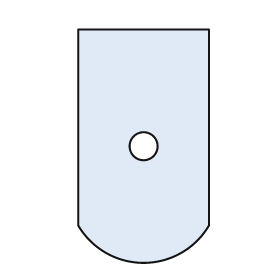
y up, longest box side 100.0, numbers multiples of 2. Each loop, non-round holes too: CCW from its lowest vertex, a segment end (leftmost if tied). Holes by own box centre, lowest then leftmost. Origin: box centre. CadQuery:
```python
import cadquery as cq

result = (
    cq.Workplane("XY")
    .moveTo(-28.0, -34.0)
    .threePointArc((0.0, -50.0), (28.0, -34.0))
    .lineTo(28.0, 50.0)
    .lineTo(-28.0, 50.0)
    .close()
    .moveTo(0.0, 0.0)
    .circle(6.0)
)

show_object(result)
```